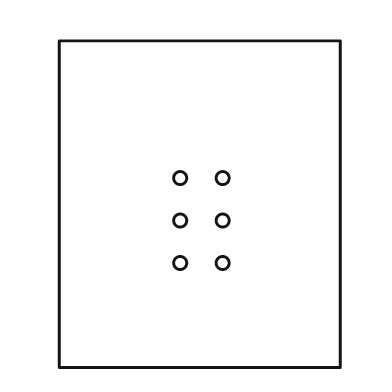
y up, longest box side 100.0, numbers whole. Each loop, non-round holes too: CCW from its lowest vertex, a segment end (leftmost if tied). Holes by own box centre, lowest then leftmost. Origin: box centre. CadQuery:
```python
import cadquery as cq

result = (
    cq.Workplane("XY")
    .moveTo(-43.0, -50.0)
    .lineTo(43.0, -50.0)
    .lineTo(43.0, 50.0)
    .lineTo(-43.0, 50.0)
    .close()
    .moveTo(-6.0, -18.0)
    .circle(2.0)
    .moveTo(7.0, -18.0)
    .circle(2.0)
    .moveTo(-6.0, -5.0)
    .circle(2.0)
    .moveTo(7.0, -5.0)
    .circle(2.0)
    .moveTo(-6.0, 8.0)
    .circle(2.0)
    .moveTo(7.0, 8.0)
    .circle(2.0)
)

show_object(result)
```